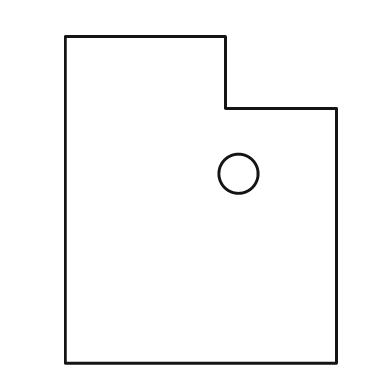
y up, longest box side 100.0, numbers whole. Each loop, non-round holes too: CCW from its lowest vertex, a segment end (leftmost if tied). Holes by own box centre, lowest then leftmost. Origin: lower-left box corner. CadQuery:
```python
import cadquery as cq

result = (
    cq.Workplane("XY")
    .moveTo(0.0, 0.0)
    .lineTo(83.0, 0.0)
    .lineTo(83.0, 78.0)
    .lineTo(49.0, 78.0)
    .lineTo(49.0, 100.0)
    .lineTo(0.0, 100.0)
    .close()
    .moveTo(53.0, 58.0)
    .circle(6.0)
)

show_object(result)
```